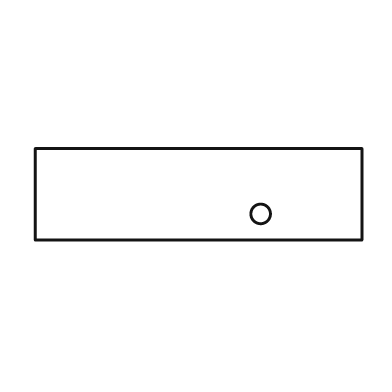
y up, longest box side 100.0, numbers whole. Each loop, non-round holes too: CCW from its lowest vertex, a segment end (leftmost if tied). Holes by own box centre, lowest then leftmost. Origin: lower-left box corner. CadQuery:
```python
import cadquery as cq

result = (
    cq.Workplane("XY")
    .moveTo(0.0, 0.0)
    .lineTo(100.0, 0.0)
    .lineTo(100.0, 28.0)
    .lineTo(0.0, 28.0)
    .close()
    .moveTo(69.0, 8.0)
    .circle(3.0)
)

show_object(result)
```